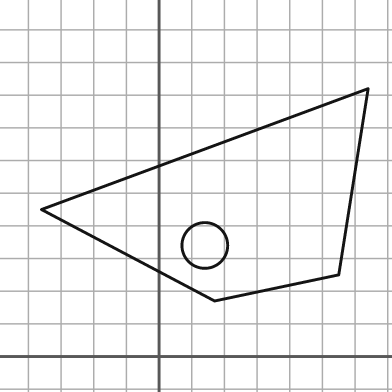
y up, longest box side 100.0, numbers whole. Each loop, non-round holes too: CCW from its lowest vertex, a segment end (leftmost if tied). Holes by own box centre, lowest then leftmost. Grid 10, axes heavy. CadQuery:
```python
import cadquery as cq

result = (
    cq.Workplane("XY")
    .moveTo(17.0, 17.0)
    .lineTo(55.0, 25.0)
    .lineTo(64.0, 82.0)
    .lineTo(-36.0, 45.0)
    .close()
    .moveTo(14.0, 34.0)
    .circle(7.0)
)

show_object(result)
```